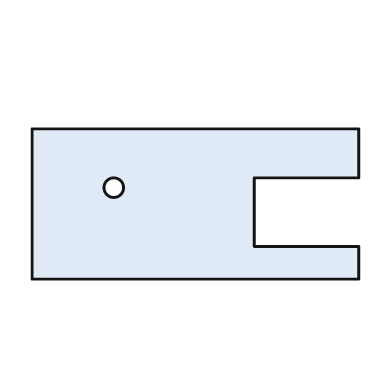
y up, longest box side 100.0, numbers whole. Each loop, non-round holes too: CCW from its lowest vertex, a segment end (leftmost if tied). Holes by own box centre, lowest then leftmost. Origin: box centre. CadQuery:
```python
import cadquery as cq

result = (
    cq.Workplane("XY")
    .moveTo(-50.0, -23.0)
    .lineTo(50.0, -23.0)
    .lineTo(50.0, -13.0)
    .lineTo(18.0, -13.0)
    .lineTo(18.0, 8.0)
    .lineTo(50.0, 8.0)
    .lineTo(50.0, 23.0)
    .lineTo(-50.0, 23.0)
    .close()
    .moveTo(-25.0, 5.0)
    .circle(3.0)
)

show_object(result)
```